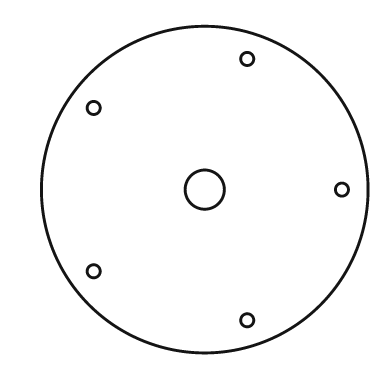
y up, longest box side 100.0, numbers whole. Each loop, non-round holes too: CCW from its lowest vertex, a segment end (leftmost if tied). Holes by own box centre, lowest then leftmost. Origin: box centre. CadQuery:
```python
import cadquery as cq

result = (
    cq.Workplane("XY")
    .moveTo(0.0, 0.0)
    .circle(50.0)
    .moveTo(13.0, -40.0)
    .circle(2.0)
    .moveTo(-34.0, -25.0)
    .circle(2.0)
    .moveTo(0.0, 0.0)
    .circle(6.0)
    .moveTo(42.0, 0.0)
    .circle(2.0)
    .moveTo(-34.0, 25.0)
    .circle(2.0)
    .moveTo(13.0, 40.0)
    .circle(2.0)
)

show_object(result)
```